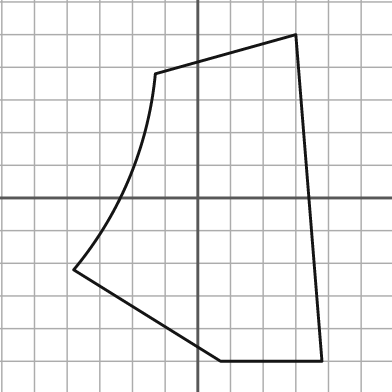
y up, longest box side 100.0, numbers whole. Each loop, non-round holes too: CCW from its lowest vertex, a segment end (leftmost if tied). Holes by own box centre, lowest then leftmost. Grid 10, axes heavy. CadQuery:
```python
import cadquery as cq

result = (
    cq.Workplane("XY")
    .moveTo(7.0, -50.0)
    .lineTo(38.0, -50.0)
    .lineTo(30.0, 50.0)
    .lineTo(-13.0, 38.0)
    .threePointArc((-21.0, 6.0), (-38.0, -22.0))
    .close()
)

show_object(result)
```